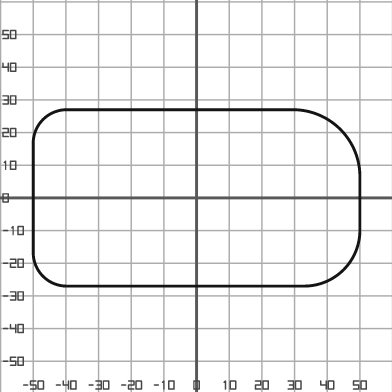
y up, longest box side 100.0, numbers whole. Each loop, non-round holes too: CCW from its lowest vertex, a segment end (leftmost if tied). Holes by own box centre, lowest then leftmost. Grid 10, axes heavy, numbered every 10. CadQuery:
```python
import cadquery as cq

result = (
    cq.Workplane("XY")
    .moveTo(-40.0, -27.0)
    .lineTo(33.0, -27.0)
    .threePointArc((45.0, -22.0), (50.0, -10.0))
    .lineTo(50.0, 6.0)
    .threePointArc((44.0, 21.0), (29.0, 27.0))
    .lineTo(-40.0, 27.0)
    .threePointArc((-47.0, 24.0), (-50.0, 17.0))
    .lineTo(-50.0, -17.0)
    .threePointArc((-47.0, -24.0), (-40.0, -27.0))
    .close()
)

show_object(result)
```